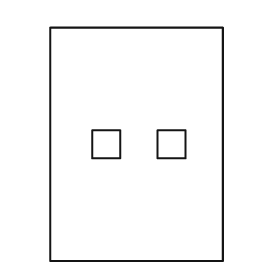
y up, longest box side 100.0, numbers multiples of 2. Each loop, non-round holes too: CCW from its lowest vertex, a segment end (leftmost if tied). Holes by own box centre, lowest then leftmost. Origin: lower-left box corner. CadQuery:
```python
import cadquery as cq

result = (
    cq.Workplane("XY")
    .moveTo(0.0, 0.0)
    .lineTo(74.0, 0.0)
    .lineTo(74.0, 100.0)
    .lineTo(0.0, 100.0)
    .close()
    .moveTo(18.0, 44.0)
    .lineTo(30.0, 44.0)
    .lineTo(30.0, 56.0)
    .lineTo(18.0, 56.0)
    .close()
    .moveTo(46.0, 44.0)
    .lineTo(58.0, 44.0)
    .lineTo(58.0, 56.0)
    .lineTo(46.0, 56.0)
    .close()
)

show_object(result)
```